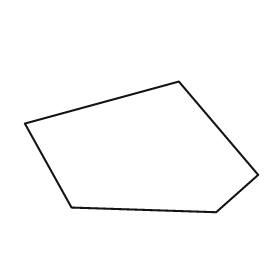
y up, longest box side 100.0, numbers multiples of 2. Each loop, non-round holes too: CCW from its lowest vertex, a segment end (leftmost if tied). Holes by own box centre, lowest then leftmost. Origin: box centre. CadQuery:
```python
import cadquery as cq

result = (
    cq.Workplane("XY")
    .moveTo(32.0, -28.0)
    .lineTo(50.0, -12.0)
    .lineTo(16.0, 28.0)
    .lineTo(-50.0, 10.0)
    .lineTo(-30.0, -26.0)
    .close()
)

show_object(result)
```